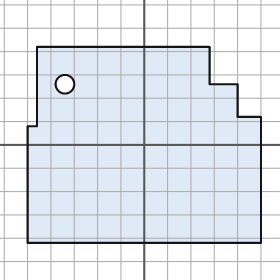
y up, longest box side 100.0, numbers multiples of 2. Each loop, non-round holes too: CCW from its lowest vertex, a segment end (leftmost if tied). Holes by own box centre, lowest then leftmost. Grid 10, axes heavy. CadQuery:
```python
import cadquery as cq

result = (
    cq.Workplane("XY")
    .moveTo(-50.0, -42.0)
    .lineTo(50.0, -42.0)
    .lineTo(50.0, 12.0)
    .lineTo(40.0, 12.0)
    .lineTo(40.0, 26.0)
    .lineTo(28.0, 26.0)
    .lineTo(28.0, 42.0)
    .lineTo(-46.0, 42.0)
    .lineTo(-46.0, 8.0)
    .lineTo(-50.0, 8.0)
    .close()
    .moveTo(-34.0, 26.0)
    .circle(4.0)
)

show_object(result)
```